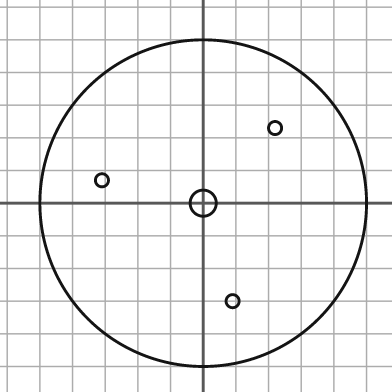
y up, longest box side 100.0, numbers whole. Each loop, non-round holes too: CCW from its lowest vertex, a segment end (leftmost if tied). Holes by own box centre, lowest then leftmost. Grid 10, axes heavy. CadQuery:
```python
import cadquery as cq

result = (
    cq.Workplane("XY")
    .moveTo(0.0, 0.0)
    .circle(50.0)
    .moveTo(9.0, -30.0)
    .circle(2.0)
    .moveTo(0.0, 0.0)
    .circle(4.0)
    .moveTo(-31.0, 7.0)
    .circle(2.0)
    .moveTo(22.0, 23.0)
    .circle(2.0)
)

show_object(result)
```